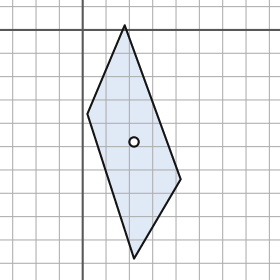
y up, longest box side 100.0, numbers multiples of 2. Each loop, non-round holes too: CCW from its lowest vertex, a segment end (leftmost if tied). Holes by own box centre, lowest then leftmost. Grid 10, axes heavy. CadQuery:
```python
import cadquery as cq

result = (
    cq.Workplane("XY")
    .moveTo(22.0, -98.0)
    .lineTo(42.0, -64.0)
    .lineTo(18.0, 2.0)
    .lineTo(2.0, -36.0)
    .close()
    .moveTo(22.0, -48.0)
    .circle(2.0)
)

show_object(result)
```